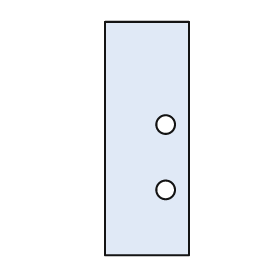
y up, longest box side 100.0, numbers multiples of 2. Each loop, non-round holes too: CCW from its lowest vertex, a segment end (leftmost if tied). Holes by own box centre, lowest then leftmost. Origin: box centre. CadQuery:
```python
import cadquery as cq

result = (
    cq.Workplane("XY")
    .moveTo(-18.0, -50.0)
    .lineTo(18.0, -50.0)
    .lineTo(18.0, 50.0)
    .lineTo(-18.0, 50.0)
    .close()
    .moveTo(8.0, -22.0)
    .circle(4.0)
    .moveTo(8.0, 6.0)
    .circle(4.0)
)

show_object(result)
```